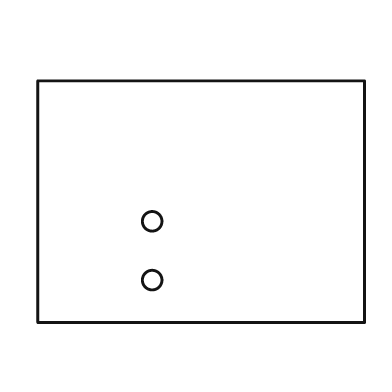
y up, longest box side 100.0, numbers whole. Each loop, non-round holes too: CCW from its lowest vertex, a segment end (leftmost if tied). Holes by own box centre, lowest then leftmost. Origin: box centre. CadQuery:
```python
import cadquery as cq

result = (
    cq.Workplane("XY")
    .moveTo(-50.0, -37.0)
    .lineTo(50.0, -37.0)
    .lineTo(50.0, 37.0)
    .lineTo(-50.0, 37.0)
    .close()
    .moveTo(-15.0, -24.0)
    .circle(3.0)
    .moveTo(-15.0, -6.0)
    .circle(3.0)
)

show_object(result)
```